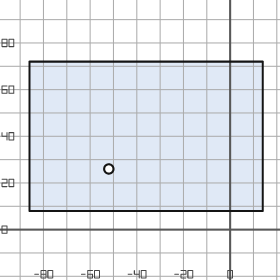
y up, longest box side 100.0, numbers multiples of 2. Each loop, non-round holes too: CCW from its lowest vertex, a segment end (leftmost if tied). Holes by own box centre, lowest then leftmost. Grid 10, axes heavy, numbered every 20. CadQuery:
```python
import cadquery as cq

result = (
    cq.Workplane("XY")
    .moveTo(-86.0, 8.0)
    .lineTo(14.0, 8.0)
    .lineTo(14.0, 72.0)
    .lineTo(-86.0, 72.0)
    .close()
    .moveTo(-52.0, 26.0)
    .circle(2.0)
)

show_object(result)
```